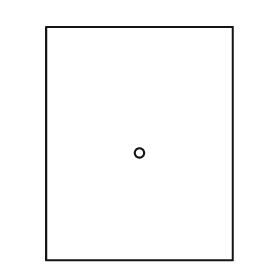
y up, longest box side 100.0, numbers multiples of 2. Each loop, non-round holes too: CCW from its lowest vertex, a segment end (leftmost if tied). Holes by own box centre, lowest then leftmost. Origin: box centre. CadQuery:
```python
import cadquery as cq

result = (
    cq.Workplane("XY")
    .moveTo(-40.0, -50.0)
    .lineTo(40.0, -50.0)
    .lineTo(40.0, 50.0)
    .lineTo(-40.0, 50.0)
    .close()
    .moveTo(0.0, -4.0)
    .circle(2.0)
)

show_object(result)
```